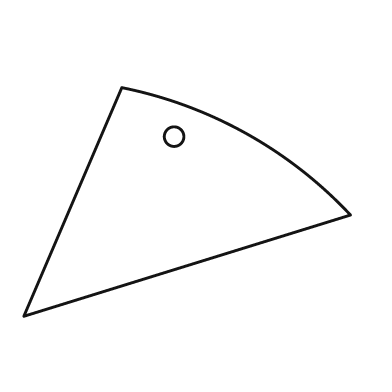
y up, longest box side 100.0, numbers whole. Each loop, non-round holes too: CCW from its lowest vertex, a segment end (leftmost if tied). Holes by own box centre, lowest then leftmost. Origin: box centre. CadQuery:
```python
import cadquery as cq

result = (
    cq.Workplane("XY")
    .moveTo(-50.0, -35.0)
    .lineTo(50.0, -4.0)
    .threePointArc((18.0, 21.0), (-20.0, 35.0))
    .close()
    .moveTo(-4.0, 20.0)
    .circle(3.0)
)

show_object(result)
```